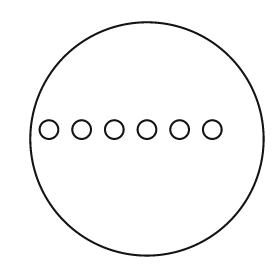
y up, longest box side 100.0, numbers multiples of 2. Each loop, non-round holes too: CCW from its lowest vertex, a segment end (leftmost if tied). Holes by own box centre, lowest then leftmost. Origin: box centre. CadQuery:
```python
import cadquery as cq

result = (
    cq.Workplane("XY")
    .moveTo(0.0, 0.0)
    .circle(50.0)
    .moveTo(-42.0, 4.0)
    .circle(4.0)
    .moveTo(-28.0, 4.0)
    .circle(4.0)
    .moveTo(-14.0, 4.0)
    .circle(4.0)
    .moveTo(0.0, 4.0)
    .circle(4.0)
    .moveTo(14.0, 4.0)
    .circle(4.0)
    .moveTo(28.0, 4.0)
    .circle(4.0)
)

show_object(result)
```